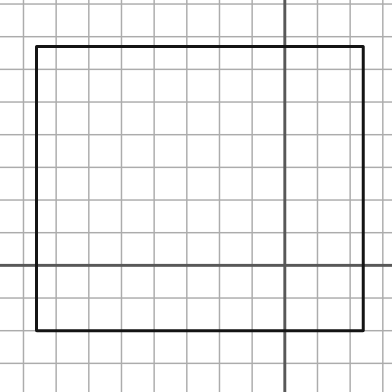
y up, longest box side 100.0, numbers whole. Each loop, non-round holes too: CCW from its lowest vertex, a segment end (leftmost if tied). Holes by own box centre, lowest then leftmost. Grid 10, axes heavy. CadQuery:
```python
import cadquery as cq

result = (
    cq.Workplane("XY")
    .moveTo(-76.0, -20.0)
    .lineTo(24.0, -20.0)
    .lineTo(24.0, 67.0)
    .lineTo(-76.0, 67.0)
    .close()
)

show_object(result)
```